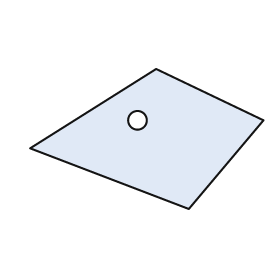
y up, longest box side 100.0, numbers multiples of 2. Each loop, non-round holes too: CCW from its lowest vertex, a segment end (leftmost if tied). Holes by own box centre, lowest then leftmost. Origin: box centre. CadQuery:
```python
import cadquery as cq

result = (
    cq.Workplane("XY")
    .moveTo(18.0, -30.0)
    .lineTo(50.0, 8.0)
    .lineTo(4.0, 30.0)
    .lineTo(-50.0, -4.0)
    .close()
    .moveTo(-4.0, 8.0)
    .circle(4.0)
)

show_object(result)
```